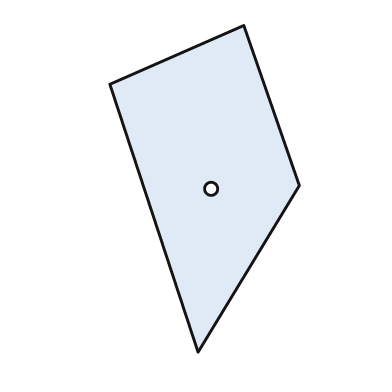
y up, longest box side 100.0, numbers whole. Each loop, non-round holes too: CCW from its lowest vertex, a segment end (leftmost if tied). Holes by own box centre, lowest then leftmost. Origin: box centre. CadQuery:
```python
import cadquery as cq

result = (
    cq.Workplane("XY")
    .moveTo(-2.0, -50.0)
    .lineTo(29.0, 1.0)
    .lineTo(12.0, 50.0)
    .lineTo(-29.0, 32.0)
    .close()
    .moveTo(2.0, 0.0)
    .circle(2.0)
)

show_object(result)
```